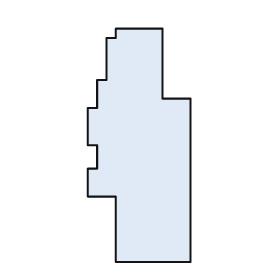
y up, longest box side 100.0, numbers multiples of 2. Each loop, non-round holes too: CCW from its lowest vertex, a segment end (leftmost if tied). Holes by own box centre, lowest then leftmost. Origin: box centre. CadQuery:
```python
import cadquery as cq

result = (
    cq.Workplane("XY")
    .moveTo(-10.0, -50.0)
    .lineTo(22.0, -50.0)
    .lineTo(22.0, 20.0)
    .lineTo(10.0, 20.0)
    .lineTo(10.0, 50.0)
    .lineTo(-10.0, 50.0)
    .lineTo(-10.0, 46.0)
    .lineTo(-14.0, 46.0)
    .lineTo(-14.0, 28.0)
    .lineTo(-18.0, 28.0)
    .lineTo(-18.0, 16.0)
    .lineTo(-22.0, 16.0)
    .lineTo(-22.0, 0.0)
    .lineTo(-18.0, 0.0)
    .lineTo(-18.0, -10.0)
    .lineTo(-22.0, -10.0)
    .lineTo(-22.0, -22.0)
    .lineTo(-10.0, -22.0)
    .close()
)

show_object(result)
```